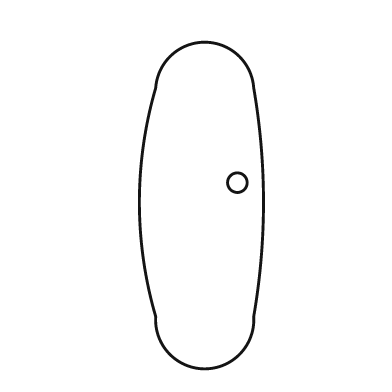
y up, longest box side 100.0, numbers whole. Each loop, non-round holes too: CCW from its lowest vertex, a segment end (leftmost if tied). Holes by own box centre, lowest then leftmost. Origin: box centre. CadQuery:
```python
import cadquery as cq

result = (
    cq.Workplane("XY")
    .moveTo(-14.0, -34.0)
    .threePointArc((1.0, -50.0), (16.0, -34.0))
    .threePointArc((19.0, 1.0), (16.0, 36.0))
    .threePointArc((1.0, 50.0), (-14.0, 36.0))
    .threePointArc((-19.0, 1.0), (-14.0, -34.0))
    .close()
    .moveTo(11.0, 7.0)
    .circle(3.0)
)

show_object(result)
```